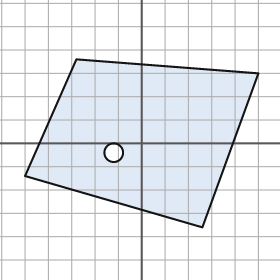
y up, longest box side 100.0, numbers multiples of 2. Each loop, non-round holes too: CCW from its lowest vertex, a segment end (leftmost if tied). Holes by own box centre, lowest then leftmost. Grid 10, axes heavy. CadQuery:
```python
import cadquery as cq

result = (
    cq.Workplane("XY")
    .moveTo(26.0, -36.0)
    .lineTo(50.0, 30.0)
    .lineTo(-28.0, 36.0)
    .lineTo(-50.0, -14.0)
    .close()
    .moveTo(-12.0, -4.0)
    .circle(4.0)
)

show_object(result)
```